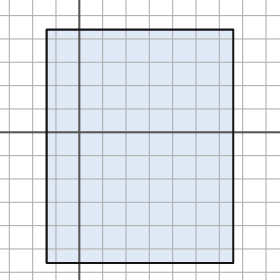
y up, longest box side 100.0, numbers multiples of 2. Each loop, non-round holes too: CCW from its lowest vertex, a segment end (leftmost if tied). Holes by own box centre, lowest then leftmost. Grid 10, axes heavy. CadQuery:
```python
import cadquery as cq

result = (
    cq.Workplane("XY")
    .moveTo(-14.0, -56.0)
    .lineTo(66.0, -56.0)
    .lineTo(66.0, 44.0)
    .lineTo(-14.0, 44.0)
    .close()
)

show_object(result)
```